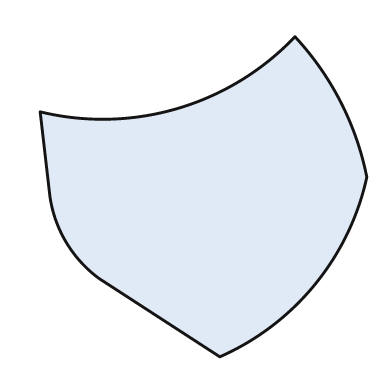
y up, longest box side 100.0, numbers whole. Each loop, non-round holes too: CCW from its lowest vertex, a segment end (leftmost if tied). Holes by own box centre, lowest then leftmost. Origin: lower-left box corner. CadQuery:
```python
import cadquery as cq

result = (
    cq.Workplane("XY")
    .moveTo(55.0, 0.0)
    .threePointArc((84.0, 22.0), (100.0, 55.0))
    .threePointArc((92.0, 78.0), (78.0, 98.0))
    .threePointArc((42.0, 76.0), (0.0, 75.0))
    .lineTo(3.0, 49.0)
    .threePointArc((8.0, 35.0), (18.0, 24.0))
    .close()
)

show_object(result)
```